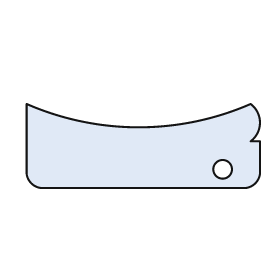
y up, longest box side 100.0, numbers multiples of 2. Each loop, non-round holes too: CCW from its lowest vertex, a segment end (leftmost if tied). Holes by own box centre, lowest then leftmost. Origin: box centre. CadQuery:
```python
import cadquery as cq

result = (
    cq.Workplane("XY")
    .moveTo(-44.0, -18.0)
    .lineTo(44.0, -18.0)
    .threePointArc((48.0, -16.0), (50.0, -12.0))
    .lineTo(50.0, 2.0)
    .lineTo(46.0, 2.0)
    .threePointArc((50.0, 10.0), (46.0, 18.0))
    .threePointArc((-2.0, 8.0), (-50.0, 18.0))
    .lineTo(-50.0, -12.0)
    .threePointArc((-48.0, -16.0), (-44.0, -18.0))
    .close()
    .moveTo(34.0, -10.0)
    .circle(4.0)
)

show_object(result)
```